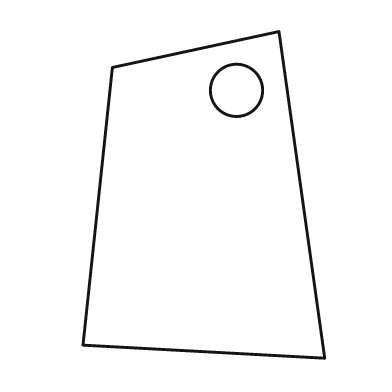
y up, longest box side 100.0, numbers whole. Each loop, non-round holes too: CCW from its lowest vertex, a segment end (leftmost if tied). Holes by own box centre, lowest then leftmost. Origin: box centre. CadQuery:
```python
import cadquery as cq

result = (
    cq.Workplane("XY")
    .moveTo(37.0, -50.0)
    .lineTo(23.0, 50.0)
    .lineTo(-28.0, 39.0)
    .lineTo(-37.0, -46.0)
    .close()
    .moveTo(10.0, 32.0)
    .circle(8.0)
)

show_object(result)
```